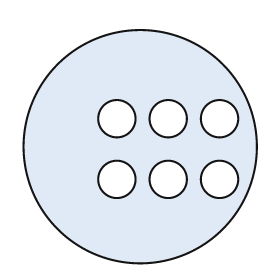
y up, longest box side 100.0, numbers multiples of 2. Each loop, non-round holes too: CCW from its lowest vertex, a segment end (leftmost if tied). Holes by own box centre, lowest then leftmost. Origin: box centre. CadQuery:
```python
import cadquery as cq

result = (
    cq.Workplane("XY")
    .moveTo(0.0, 0.0)
    .circle(50.0)
    .moveTo(-10.0, -14.0)
    .circle(8.0)
    .moveTo(12.0, -14.0)
    .circle(8.0)
    .moveTo(34.0, -14.0)
    .circle(8.0)
    .moveTo(-10.0, 12.0)
    .circle(8.0)
    .moveTo(12.0, 12.0)
    .circle(8.0)
    .moveTo(34.0, 12.0)
    .circle(8.0)
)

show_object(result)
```